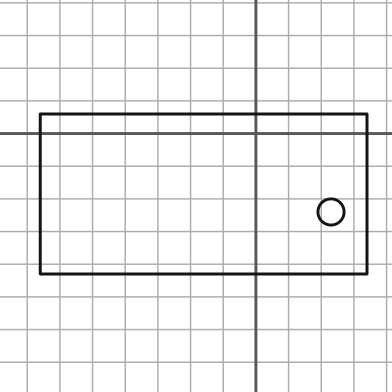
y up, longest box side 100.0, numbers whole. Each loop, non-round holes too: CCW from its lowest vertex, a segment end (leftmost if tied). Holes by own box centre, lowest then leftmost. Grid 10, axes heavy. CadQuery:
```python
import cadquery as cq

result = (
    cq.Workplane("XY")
    .moveTo(-66.0, -43.0)
    .lineTo(34.0, -43.0)
    .lineTo(34.0, 6.0)
    .lineTo(-66.0, 6.0)
    .close()
    .moveTo(23.0, -24.0)
    .circle(4.0)
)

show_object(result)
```